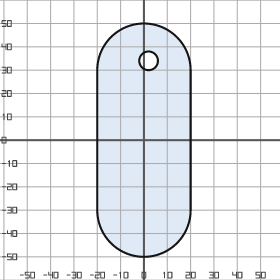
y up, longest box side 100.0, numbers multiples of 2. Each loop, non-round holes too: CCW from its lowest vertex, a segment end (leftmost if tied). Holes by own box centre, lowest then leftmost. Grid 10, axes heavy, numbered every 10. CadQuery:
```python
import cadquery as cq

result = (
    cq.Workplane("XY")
    .moveTo(-20.0, -30.0)
    .threePointArc((0.0, -50.0), (20.0, -30.0))
    .lineTo(20.0, 30.0)
    .threePointArc((0.0, 50.0), (-20.0, 30.0))
    .close()
    .moveTo(2.0, 34.0)
    .circle(4.0)
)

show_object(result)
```